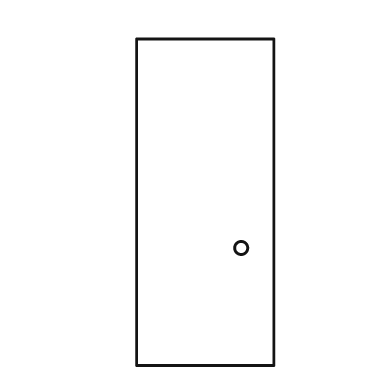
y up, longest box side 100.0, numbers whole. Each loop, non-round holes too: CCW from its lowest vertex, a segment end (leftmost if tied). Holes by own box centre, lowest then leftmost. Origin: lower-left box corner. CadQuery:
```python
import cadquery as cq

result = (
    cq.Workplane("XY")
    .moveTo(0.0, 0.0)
    .lineTo(42.0, 0.0)
    .lineTo(42.0, 100.0)
    .lineTo(0.0, 100.0)
    .close()
    .moveTo(32.0, 36.0)
    .circle(2.0)
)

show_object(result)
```